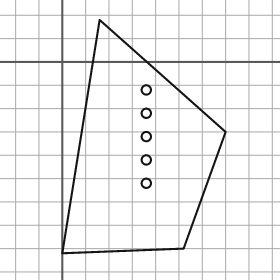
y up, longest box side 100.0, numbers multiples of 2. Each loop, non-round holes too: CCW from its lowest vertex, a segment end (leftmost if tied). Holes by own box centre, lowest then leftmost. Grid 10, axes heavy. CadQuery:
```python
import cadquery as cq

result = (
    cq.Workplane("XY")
    .moveTo(0.0, -82.0)
    .lineTo(52.0, -80.0)
    .lineTo(70.0, -30.0)
    .lineTo(16.0, 18.0)
    .close()
    .moveTo(36.0, -52.0)
    .circle(2.0)
    .moveTo(36.0, -42.0)
    .circle(2.0)
    .moveTo(36.0, -32.0)
    .circle(2.0)
    .moveTo(36.0, -22.0)
    .circle(2.0)
    .moveTo(36.0, -12.0)
    .circle(2.0)
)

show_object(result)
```